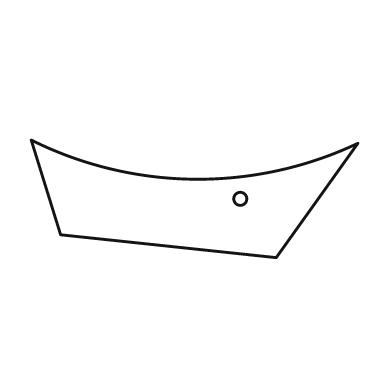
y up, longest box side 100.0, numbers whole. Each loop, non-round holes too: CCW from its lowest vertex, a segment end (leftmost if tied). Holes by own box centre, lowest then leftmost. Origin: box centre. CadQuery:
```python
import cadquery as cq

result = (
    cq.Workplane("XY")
    .moveTo(25.0, -18.0)
    .lineTo(50.0, 17.0)
    .threePointArc((0.0, 6.0), (-50.0, 18.0))
    .lineTo(-41.0, -11.0)
    .close()
    .moveTo(14.0, 0.0)
    .circle(2.0)
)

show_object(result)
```